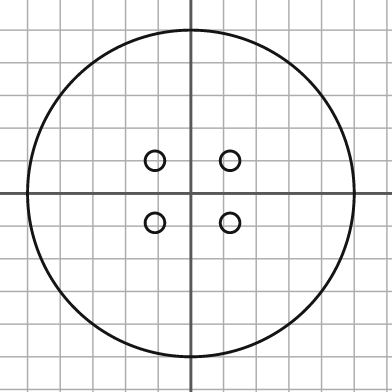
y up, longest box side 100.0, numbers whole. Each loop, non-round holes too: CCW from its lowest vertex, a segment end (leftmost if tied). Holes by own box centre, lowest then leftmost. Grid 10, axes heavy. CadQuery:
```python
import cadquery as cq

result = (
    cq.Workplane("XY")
    .moveTo(0.0, 0.0)
    .circle(50.0)
    .moveTo(-11.0, -9.0)
    .circle(3.0)
    .moveTo(12.0, -9.0)
    .circle(3.0)
    .moveTo(-11.0, 10.0)
    .circle(3.0)
    .moveTo(12.0, 10.0)
    .circle(3.0)
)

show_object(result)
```